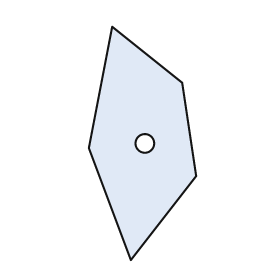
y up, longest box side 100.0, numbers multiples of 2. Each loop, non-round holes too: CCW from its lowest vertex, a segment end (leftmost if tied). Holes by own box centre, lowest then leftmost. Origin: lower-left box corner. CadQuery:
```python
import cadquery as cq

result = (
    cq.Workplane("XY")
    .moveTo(18.0, 0.0)
    .lineTo(46.0, 36.0)
    .lineTo(40.0, 76.0)
    .lineTo(10.0, 100.0)
    .lineTo(0.0, 48.0)
    .close()
    .moveTo(24.0, 50.0)
    .circle(4.0)
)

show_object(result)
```